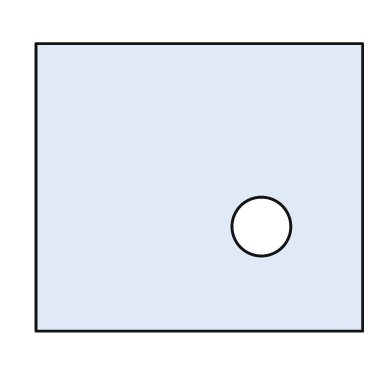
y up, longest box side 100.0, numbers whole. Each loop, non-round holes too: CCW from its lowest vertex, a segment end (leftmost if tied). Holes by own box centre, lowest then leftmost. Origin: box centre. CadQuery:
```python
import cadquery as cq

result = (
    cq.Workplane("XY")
    .moveTo(-50.0, -44.0)
    .lineTo(50.0, -44.0)
    .lineTo(50.0, 44.0)
    .lineTo(-50.0, 44.0)
    .close()
    .moveTo(19.0, -12.0)
    .circle(9.0)
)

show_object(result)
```